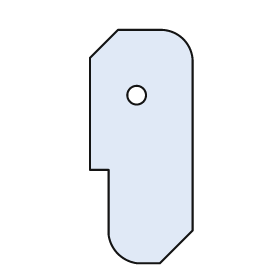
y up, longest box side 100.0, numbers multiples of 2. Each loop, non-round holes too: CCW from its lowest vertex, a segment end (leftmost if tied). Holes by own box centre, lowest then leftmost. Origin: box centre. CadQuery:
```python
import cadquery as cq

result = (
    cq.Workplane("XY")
    .moveTo(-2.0, -50.0)
    .lineTo(8.0, -50.0)
    .lineTo(22.0, -36.0)
    .lineTo(22.0, 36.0)
    .threePointArc((18.0, 46.0), (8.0, 50.0))
    .lineTo(-10.0, 50.0)
    .lineTo(-22.0, 38.0)
    .lineTo(-22.0, -10.0)
    .lineTo(-14.0, -10.0)
    .lineTo(-14.0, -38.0)
    .threePointArc((-10.0, -46.0), (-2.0, -50.0))
    .close()
    .moveTo(-2.0, 22.0)
    .circle(4.0)
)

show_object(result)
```